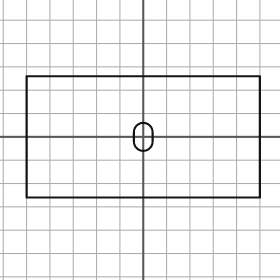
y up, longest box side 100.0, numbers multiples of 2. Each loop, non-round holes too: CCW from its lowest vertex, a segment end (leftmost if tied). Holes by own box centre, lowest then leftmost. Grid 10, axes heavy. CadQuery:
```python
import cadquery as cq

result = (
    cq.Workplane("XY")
    .moveTo(-50.0, -26.0)
    .lineTo(50.0, -26.0)
    .lineTo(50.0, 26.0)
    .lineTo(-50.0, 26.0)
    .close()
    .moveTo(-4.0, -2.0)
    .threePointArc((0.0, -6.0), (4.0, -2.0))
    .lineTo(4.0, 2.0)
    .threePointArc((0.0, 6.0), (-4.0, 2.0))
    .close()
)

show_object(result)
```